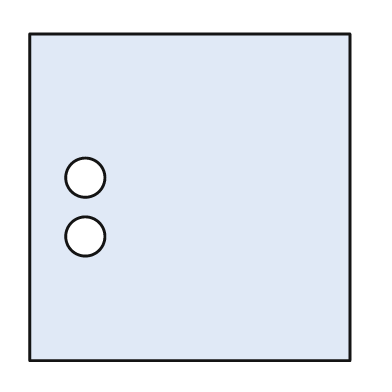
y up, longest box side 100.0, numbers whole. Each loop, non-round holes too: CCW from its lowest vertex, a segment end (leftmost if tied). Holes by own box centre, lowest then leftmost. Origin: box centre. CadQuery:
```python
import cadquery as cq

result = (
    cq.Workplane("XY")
    .moveTo(-49.0, -50.0)
    .lineTo(49.0, -50.0)
    .lineTo(49.0, 50.0)
    .lineTo(-49.0, 50.0)
    .close()
    .moveTo(-32.0, -12.0)
    .circle(6.0)
    .moveTo(-32.0, 6.0)
    .circle(6.0)
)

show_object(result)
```